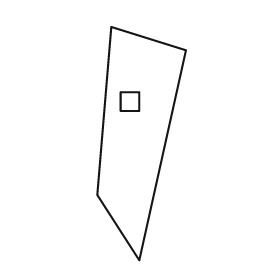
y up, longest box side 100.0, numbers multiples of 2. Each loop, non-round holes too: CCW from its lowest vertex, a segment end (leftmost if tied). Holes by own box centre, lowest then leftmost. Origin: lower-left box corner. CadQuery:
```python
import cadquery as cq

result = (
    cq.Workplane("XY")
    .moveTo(18.0, 0.0)
    .lineTo(38.0, 90.0)
    .lineTo(6.0, 100.0)
    .lineTo(0.0, 28.0)
    .close()
    .moveTo(10.0, 64.0)
    .lineTo(18.0, 64.0)
    .lineTo(18.0, 72.0)
    .lineTo(10.0, 72.0)
    .close()
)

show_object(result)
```